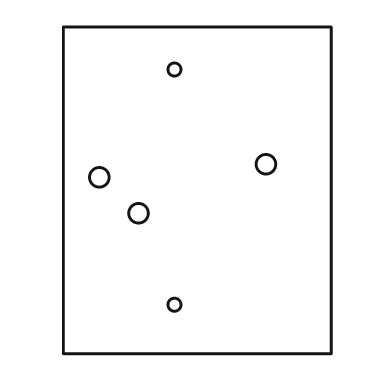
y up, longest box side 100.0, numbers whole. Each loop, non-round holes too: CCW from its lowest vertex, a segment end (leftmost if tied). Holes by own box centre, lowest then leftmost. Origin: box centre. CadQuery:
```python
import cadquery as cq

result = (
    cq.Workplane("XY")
    .moveTo(-41.0, -50.0)
    .lineTo(41.0, -50.0)
    .lineTo(41.0, 50.0)
    .lineTo(-41.0, 50.0)
    .close()
    .moveTo(-7.0, -35.0)
    .circle(2.0)
    .moveTo(-18.0, -7.0)
    .circle(3.0)
    .moveTo(-30.0, 4.0)
    .circle(3.0)
    .moveTo(21.0, 8.0)
    .circle(3.0)
    .moveTo(-7.0, 37.0)
    .circle(2.0)
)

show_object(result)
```